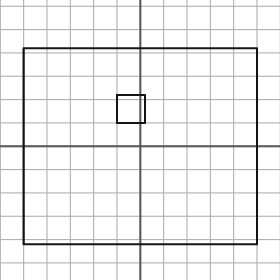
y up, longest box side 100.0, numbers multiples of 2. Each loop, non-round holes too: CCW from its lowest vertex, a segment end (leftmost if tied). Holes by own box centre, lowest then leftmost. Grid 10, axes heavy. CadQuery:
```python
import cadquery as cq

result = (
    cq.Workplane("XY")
    .moveTo(-50.0, -42.0)
    .lineTo(50.0, -42.0)
    .lineTo(50.0, 42.0)
    .lineTo(-50.0, 42.0)
    .close()
    .moveTo(-10.0, 10.0)
    .lineTo(2.0, 10.0)
    .lineTo(2.0, 22.0)
    .lineTo(-10.0, 22.0)
    .close()
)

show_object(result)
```